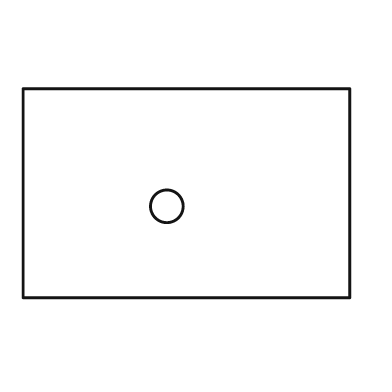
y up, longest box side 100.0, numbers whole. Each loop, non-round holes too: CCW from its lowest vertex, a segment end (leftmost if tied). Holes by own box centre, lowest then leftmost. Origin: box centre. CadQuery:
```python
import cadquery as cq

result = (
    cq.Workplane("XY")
    .moveTo(-50.0, -32.0)
    .lineTo(50.0, -32.0)
    .lineTo(50.0, 32.0)
    .lineTo(-50.0, 32.0)
    .close()
    .moveTo(-6.0, -4.0)
    .circle(5.0)
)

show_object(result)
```